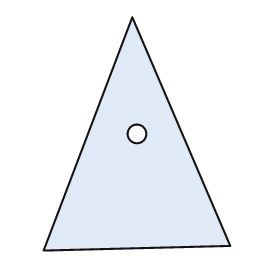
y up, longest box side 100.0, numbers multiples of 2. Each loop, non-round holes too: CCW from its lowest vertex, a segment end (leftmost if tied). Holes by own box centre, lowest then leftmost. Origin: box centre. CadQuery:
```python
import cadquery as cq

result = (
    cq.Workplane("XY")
    .moveTo(-40.0, -50.0)
    .lineTo(40.0, -48.0)
    .lineTo(-2.0, 50.0)
    .close()
    .moveTo(0.0, 0.0)
    .circle(4.0)
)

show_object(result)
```